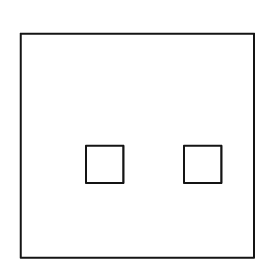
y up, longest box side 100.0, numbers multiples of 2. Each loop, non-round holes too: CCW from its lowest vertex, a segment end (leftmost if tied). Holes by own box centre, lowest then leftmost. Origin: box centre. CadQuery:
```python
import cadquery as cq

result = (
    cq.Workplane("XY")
    .moveTo(-50.0, -48.0)
    .lineTo(50.0, -48.0)
    .lineTo(50.0, 48.0)
    .lineTo(-50.0, 48.0)
    .close()
    .moveTo(-22.0, -16.0)
    .lineTo(-6.0, -16.0)
    .lineTo(-6.0, 0.0)
    .lineTo(-22.0, 0.0)
    .close()
    .moveTo(20.0, -16.0)
    .lineTo(36.0, -16.0)
    .lineTo(36.0, 0.0)
    .lineTo(20.0, 0.0)
    .close()
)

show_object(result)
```